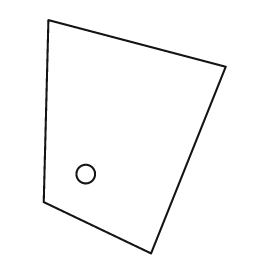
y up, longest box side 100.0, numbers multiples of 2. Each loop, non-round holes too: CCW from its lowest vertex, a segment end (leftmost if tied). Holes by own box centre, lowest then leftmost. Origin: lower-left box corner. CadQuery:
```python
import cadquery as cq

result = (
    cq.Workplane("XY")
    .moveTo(46.0, 0.0)
    .lineTo(78.0, 80.0)
    .lineTo(2.0, 100.0)
    .lineTo(0.0, 22.0)
    .close()
    .moveTo(18.0, 34.0)
    .circle(4.0)
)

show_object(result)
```